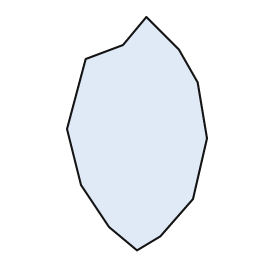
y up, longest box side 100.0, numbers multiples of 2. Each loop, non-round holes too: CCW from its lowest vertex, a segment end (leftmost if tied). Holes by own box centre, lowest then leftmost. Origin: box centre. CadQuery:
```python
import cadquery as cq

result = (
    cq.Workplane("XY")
    .moveTo(0.0, -50.0)
    .lineTo(10.0, -44.0)
    .lineTo(24.0, -28.0)
    .lineTo(30.0, -2.0)
    .lineTo(26.0, 22.0)
    .lineTo(18.0, 36.0)
    .lineTo(4.0, 50.0)
    .lineTo(-6.0, 38.0)
    .lineTo(-22.0, 32.0)
    .lineTo(-30.0, 2.0)
    .lineTo(-24.0, -22.0)
    .lineTo(-12.0, -40.0)
    .close()
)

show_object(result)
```